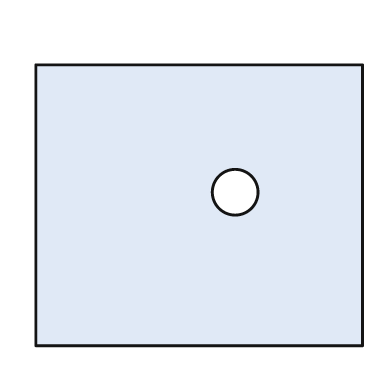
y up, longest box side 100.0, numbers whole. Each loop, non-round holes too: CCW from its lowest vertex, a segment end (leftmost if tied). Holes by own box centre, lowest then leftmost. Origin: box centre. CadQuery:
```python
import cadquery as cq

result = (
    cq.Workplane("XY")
    .moveTo(-50.0, -43.0)
    .lineTo(50.0, -43.0)
    .lineTo(50.0, 43.0)
    .lineTo(-50.0, 43.0)
    .close()
    .moveTo(11.0, 4.0)
    .circle(7.0)
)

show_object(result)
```